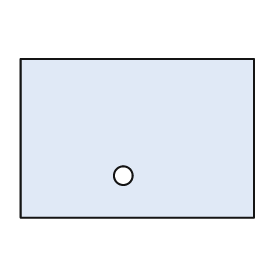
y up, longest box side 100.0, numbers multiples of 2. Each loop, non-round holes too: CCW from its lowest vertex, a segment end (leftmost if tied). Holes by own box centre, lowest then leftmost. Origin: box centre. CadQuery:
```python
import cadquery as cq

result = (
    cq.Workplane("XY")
    .moveTo(-50.0, -34.0)
    .lineTo(50.0, -34.0)
    .lineTo(50.0, 34.0)
    .lineTo(-50.0, 34.0)
    .close()
    .moveTo(-6.0, -16.0)
    .circle(4.0)
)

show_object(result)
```